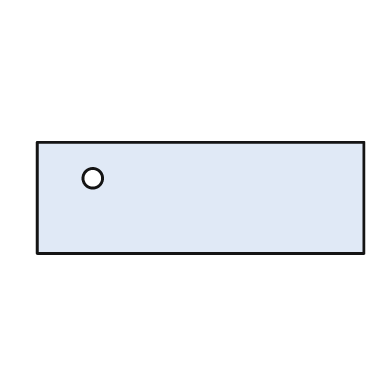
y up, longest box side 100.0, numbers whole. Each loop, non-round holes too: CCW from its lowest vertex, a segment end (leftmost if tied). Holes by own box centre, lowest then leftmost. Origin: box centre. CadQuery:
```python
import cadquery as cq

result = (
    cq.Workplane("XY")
    .moveTo(-50.0, -17.0)
    .lineTo(50.0, -17.0)
    .lineTo(50.0, 17.0)
    .lineTo(-50.0, 17.0)
    .close()
    .moveTo(-33.0, 6.0)
    .circle(3.0)
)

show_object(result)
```